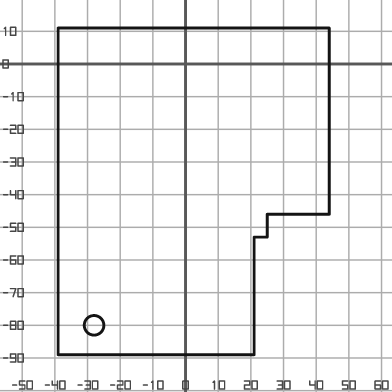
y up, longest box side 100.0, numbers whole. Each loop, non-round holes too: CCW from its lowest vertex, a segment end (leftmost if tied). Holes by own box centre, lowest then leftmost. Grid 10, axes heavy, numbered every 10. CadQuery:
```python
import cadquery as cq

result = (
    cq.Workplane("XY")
    .moveTo(-39.0, -89.0)
    .lineTo(21.0, -89.0)
    .lineTo(21.0, -53.0)
    .lineTo(25.0, -53.0)
    .lineTo(25.0, -46.0)
    .lineTo(44.0, -46.0)
    .lineTo(44.0, 11.0)
    .lineTo(-39.0, 11.0)
    .close()
    .moveTo(-28.0, -80.0)
    .circle(3.0)
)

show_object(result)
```